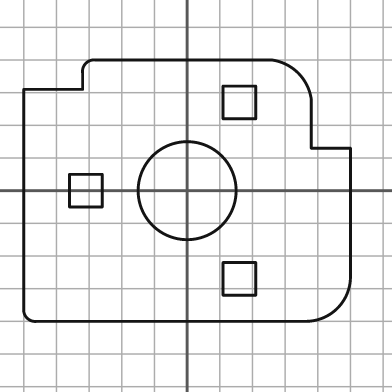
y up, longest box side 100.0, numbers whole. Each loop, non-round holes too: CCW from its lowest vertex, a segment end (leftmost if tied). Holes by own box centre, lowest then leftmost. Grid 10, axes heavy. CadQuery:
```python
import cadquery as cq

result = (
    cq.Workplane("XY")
    .moveTo(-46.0, -40.0)
    .lineTo(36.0, -40.0)
    .threePointArc((46.0, -36.0), (50.0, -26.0))
    .lineTo(50.0, 13.0)
    .lineTo(38.0, 13.0)
    .lineTo(38.0, 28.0)
    .threePointArc((34.0, 36.0), (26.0, 40.0))
    .lineTo(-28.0, 40.0)
    .threePointArc((-31.0, 39.0), (-32.0, 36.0))
    .lineTo(-32.0, 31.0)
    .lineTo(-50.0, 31.0)
    .lineTo(-50.0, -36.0)
    .threePointArc((-49.0, -39.0), (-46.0, -40.0))
    .close()
    .moveTo(11.0, -32.0)
    .lineTo(21.0, -32.0)
    .lineTo(21.0, -22.0)
    .lineTo(11.0, -22.0)
    .close()
    .moveTo(-36.0, -5.0)
    .lineTo(-26.0, -5.0)
    .lineTo(-26.0, 5.0)
    .lineTo(-36.0, 5.0)
    .close()
    .moveTo(0.0, 0.0)
    .circle(15.0)
    .moveTo(11.0, 22.0)
    .lineTo(21.0, 22.0)
    .lineTo(21.0, 32.0)
    .lineTo(11.0, 32.0)
    .close()
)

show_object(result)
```